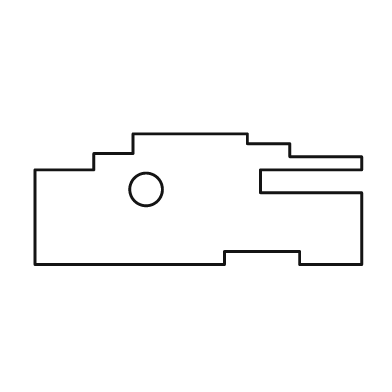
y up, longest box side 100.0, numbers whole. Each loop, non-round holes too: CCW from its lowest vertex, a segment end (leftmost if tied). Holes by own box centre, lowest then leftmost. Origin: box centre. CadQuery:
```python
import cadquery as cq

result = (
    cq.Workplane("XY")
    .moveTo(-50.0, -20.0)
    .lineTo(8.0, -20.0)
    .lineTo(8.0, -16.0)
    .lineTo(31.0, -16.0)
    .lineTo(31.0, -20.0)
    .lineTo(50.0, -20.0)
    .lineTo(50.0, 2.0)
    .lineTo(19.0, 2.0)
    .lineTo(19.0, 9.0)
    .lineTo(50.0, 9.0)
    .lineTo(50.0, 13.0)
    .lineTo(28.0, 13.0)
    .lineTo(28.0, 17.0)
    .lineTo(15.0, 17.0)
    .lineTo(15.0, 20.0)
    .lineTo(-20.0, 20.0)
    .lineTo(-20.0, 14.0)
    .lineTo(-32.0, 14.0)
    .lineTo(-32.0, 9.0)
    .lineTo(-50.0, 9.0)
    .close()
    .moveTo(-16.0, 3.0)
    .circle(5.0)
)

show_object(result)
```